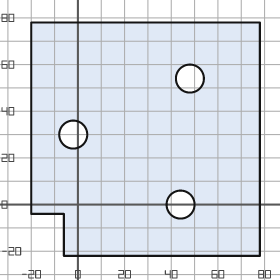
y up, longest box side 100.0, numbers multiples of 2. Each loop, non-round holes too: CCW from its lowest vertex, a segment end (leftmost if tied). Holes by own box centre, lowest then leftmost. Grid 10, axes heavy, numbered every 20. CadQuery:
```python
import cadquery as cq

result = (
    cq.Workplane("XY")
    .moveTo(-6.0, -22.0)
    .lineTo(78.0, -22.0)
    .lineTo(78.0, 78.0)
    .lineTo(-20.0, 78.0)
    .lineTo(-20.0, -4.0)
    .lineTo(-6.0, -4.0)
    .close()
    .moveTo(44.0, 0.0)
    .circle(6.0)
    .moveTo(-2.0, 30.0)
    .circle(6.0)
    .moveTo(48.0, 54.0)
    .circle(6.0)
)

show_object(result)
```